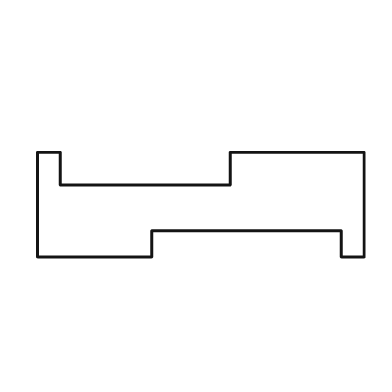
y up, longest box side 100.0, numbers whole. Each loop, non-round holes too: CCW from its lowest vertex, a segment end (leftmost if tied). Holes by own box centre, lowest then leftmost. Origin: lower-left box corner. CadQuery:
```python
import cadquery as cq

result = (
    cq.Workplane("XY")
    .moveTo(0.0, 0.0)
    .lineTo(35.0, 0.0)
    .lineTo(35.0, 8.0)
    .lineTo(93.0, 8.0)
    .lineTo(93.0, 0.0)
    .lineTo(100.0, 0.0)
    .lineTo(100.0, 32.0)
    .lineTo(59.0, 32.0)
    .lineTo(59.0, 22.0)
    .lineTo(7.0, 22.0)
    .lineTo(7.0, 32.0)
    .lineTo(0.0, 32.0)
    .close()
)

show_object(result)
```